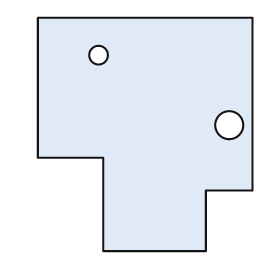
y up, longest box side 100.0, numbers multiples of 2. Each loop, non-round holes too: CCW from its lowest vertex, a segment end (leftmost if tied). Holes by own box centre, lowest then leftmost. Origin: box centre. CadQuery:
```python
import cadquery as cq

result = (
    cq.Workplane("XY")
    .moveTo(-18.0, -50.0)
    .lineTo(26.0, -50.0)
    .lineTo(26.0, -24.0)
    .lineTo(46.0, -24.0)
    .lineTo(46.0, 50.0)
    .lineTo(-46.0, 50.0)
    .lineTo(-46.0, -10.0)
    .lineTo(-18.0, -10.0)
    .close()
    .moveTo(36.0, 4.0)
    .circle(6.0)
    .moveTo(-20.0, 34.0)
    .circle(4.0)
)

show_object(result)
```